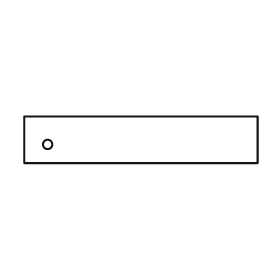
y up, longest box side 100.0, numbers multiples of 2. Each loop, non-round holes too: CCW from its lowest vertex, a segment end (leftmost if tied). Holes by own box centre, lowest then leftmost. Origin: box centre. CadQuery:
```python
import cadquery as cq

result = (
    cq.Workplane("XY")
    .moveTo(-50.0, -10.0)
    .lineTo(50.0, -10.0)
    .lineTo(50.0, 10.0)
    .lineTo(-50.0, 10.0)
    .close()
    .moveTo(-40.0, -2.0)
    .circle(2.0)
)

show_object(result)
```